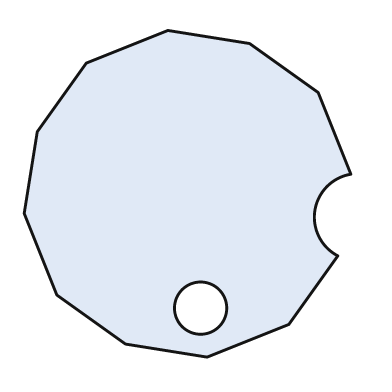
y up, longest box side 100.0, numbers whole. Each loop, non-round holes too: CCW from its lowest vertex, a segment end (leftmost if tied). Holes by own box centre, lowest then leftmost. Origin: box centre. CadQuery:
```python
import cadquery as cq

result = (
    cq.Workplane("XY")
    .moveTo(6.0, -50.0)
    .lineTo(31.0, -40.0)
    .lineTo(46.0, -19.0)
    .threePointArc((39.0, -5.0), (50.0, 6.0))
    .lineTo(40.0, 31.0)
    .lineTo(19.0, 46.0)
    .lineTo(-6.0, 50.0)
    .lineTo(-31.0, 40.0)
    .lineTo(-46.0, 19.0)
    .lineTo(-50.0, -6.0)
    .lineTo(-40.0, -31.0)
    .lineTo(-19.0, -46.0)
    .close()
    .moveTo(4.0, -35.0)
    .circle(8.0)
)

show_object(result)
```